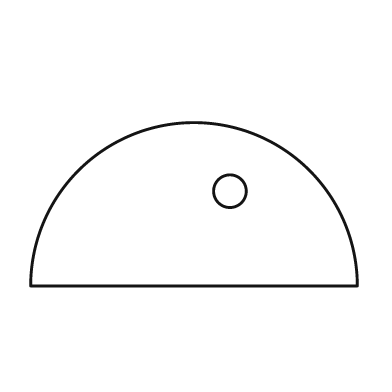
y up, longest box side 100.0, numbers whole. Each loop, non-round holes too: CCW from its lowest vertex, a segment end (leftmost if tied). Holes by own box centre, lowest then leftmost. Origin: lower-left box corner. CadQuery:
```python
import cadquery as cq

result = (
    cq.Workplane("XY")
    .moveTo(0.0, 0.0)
    .lineTo(100.0, 0.0)
    .threePointArc((50.0, 50.0), (0.0, 0.0))
    .close()
    .moveTo(61.0, 29.0)
    .circle(5.0)
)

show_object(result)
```